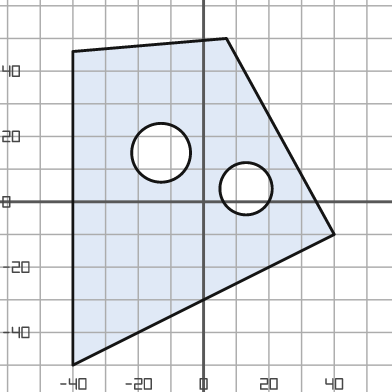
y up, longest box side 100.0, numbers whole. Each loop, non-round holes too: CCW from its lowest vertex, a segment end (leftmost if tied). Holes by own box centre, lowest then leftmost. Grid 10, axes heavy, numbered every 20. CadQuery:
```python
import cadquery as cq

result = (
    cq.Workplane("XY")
    .moveTo(-40.0, -50.0)
    .lineTo(40.0, -10.0)
    .lineTo(7.0, 50.0)
    .lineTo(-40.0, 46.0)
    .close()
    .moveTo(13.0, 4.0)
    .circle(8.0)
    .moveTo(-13.0, 15.0)
    .circle(9.0)
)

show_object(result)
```